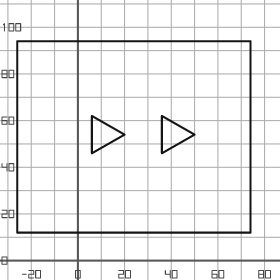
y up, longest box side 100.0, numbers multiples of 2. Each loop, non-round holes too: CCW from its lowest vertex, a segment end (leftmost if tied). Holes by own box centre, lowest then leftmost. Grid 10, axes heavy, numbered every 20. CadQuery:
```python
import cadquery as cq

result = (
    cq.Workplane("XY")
    .moveTo(-26.0, 12.0)
    .lineTo(74.0, 12.0)
    .lineTo(74.0, 94.0)
    .lineTo(-26.0, 94.0)
    .close()
    .moveTo(6.0, 46.0)
    .lineTo(20.0, 54.0)
    .lineTo(6.0, 62.0)
    .close()
    .moveTo(36.0, 46.0)
    .lineTo(50.0, 54.0)
    .lineTo(36.0, 62.0)
    .close()
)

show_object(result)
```